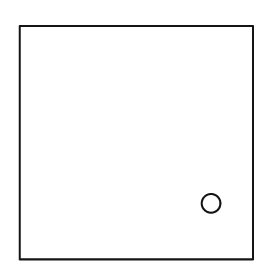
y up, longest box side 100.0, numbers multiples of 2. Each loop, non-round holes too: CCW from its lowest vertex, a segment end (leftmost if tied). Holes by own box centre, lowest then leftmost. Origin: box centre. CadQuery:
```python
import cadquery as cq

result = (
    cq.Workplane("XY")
    .moveTo(-50.0, -50.0)
    .lineTo(50.0, -50.0)
    .lineTo(50.0, 50.0)
    .lineTo(-50.0, 50.0)
    .close()
    .moveTo(32.0, -26.0)
    .circle(4.0)
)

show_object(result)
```